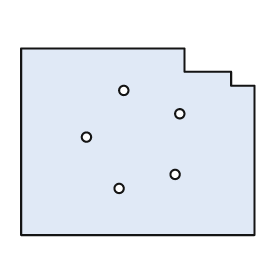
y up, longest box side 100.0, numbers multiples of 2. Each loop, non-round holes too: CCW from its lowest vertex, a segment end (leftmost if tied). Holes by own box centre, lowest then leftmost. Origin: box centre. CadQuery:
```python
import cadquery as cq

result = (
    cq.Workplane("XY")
    .moveTo(-50.0, -40.0)
    .lineTo(50.0, -40.0)
    .lineTo(50.0, 24.0)
    .lineTo(40.0, 24.0)
    .lineTo(40.0, 30.0)
    .lineTo(20.0, 30.0)
    .lineTo(20.0, 40.0)
    .lineTo(-50.0, 40.0)
    .close()
    .moveTo(-8.0, -20.0)
    .circle(2.0)
    .moveTo(16.0, -14.0)
    .circle(2.0)
    .moveTo(-22.0, 2.0)
    .circle(2.0)
    .moveTo(18.0, 12.0)
    .circle(2.0)
    .moveTo(-6.0, 22.0)
    .circle(2.0)
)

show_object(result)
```